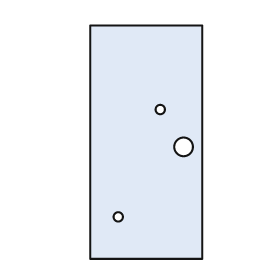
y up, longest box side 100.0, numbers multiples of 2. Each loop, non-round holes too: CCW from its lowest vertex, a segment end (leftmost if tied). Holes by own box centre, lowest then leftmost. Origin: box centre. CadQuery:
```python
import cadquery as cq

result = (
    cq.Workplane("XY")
    .moveTo(-24.0, -50.0)
    .lineTo(24.0, -50.0)
    .lineTo(24.0, 50.0)
    .lineTo(-24.0, 50.0)
    .close()
    .moveTo(-12.0, -32.0)
    .circle(2.0)
    .moveTo(16.0, -2.0)
    .circle(4.0)
    .moveTo(6.0, 14.0)
    .circle(2.0)
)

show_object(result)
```